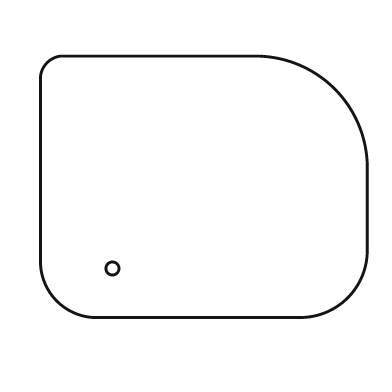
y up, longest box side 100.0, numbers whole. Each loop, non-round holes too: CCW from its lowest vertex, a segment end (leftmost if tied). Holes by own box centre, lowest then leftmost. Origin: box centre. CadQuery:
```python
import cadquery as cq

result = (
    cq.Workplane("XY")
    .moveTo(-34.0, -40.0)
    .lineTo(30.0, -40.0)
    .threePointArc((44.0, -34.0), (50.0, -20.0))
    .lineTo(50.0, 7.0)
    .threePointArc((40.0, 30.0), (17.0, 40.0))
    .lineTo(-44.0, 40.0)
    .threePointArc((-48.0, 38.0), (-50.0, 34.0))
    .lineTo(-50.0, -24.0)
    .threePointArc((-45.0, -35.0), (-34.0, -40.0))
    .close()
    .moveTo(-28.0, -25.0)
    .circle(2.0)
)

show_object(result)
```